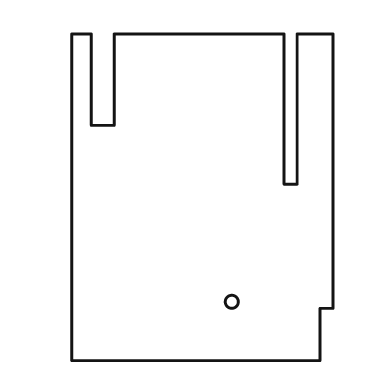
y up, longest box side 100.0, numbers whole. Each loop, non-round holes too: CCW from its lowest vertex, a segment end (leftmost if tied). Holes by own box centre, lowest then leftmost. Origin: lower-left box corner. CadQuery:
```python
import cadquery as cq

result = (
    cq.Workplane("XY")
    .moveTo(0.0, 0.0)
    .lineTo(76.0, 0.0)
    .lineTo(76.0, 16.0)
    .lineTo(80.0, 16.0)
    .lineTo(80.0, 100.0)
    .lineTo(69.0, 100.0)
    .lineTo(69.0, 54.0)
    .lineTo(65.0, 54.0)
    .lineTo(65.0, 100.0)
    .lineTo(13.0, 100.0)
    .lineTo(13.0, 72.0)
    .lineTo(6.0, 72.0)
    .lineTo(6.0, 100.0)
    .lineTo(0.0, 100.0)
    .close()
    .moveTo(49.0, 18.0)
    .circle(2.0)
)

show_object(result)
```